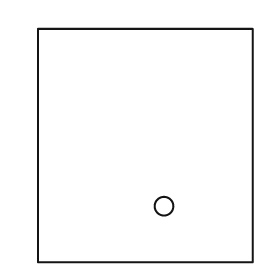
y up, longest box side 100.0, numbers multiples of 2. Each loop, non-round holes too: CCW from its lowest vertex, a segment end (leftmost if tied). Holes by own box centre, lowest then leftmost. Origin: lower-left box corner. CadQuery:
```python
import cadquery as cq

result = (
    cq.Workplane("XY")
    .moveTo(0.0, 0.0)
    .lineTo(92.0, 0.0)
    .lineTo(92.0, 100.0)
    .lineTo(0.0, 100.0)
    .close()
    .moveTo(54.0, 24.0)
    .circle(4.0)
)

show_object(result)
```